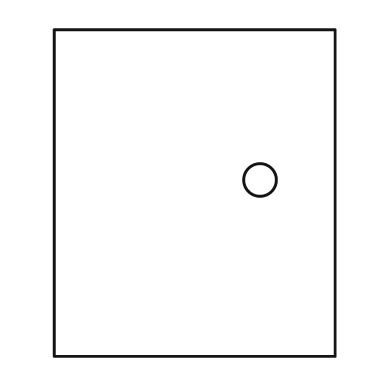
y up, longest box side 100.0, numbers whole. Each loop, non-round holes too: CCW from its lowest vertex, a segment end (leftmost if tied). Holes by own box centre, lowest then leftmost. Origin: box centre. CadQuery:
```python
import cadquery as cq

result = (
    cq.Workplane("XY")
    .moveTo(-43.0, -50.0)
    .lineTo(43.0, -50.0)
    .lineTo(43.0, 50.0)
    .lineTo(-43.0, 50.0)
    .close()
    .moveTo(20.0, 4.0)
    .circle(5.0)
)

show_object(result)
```